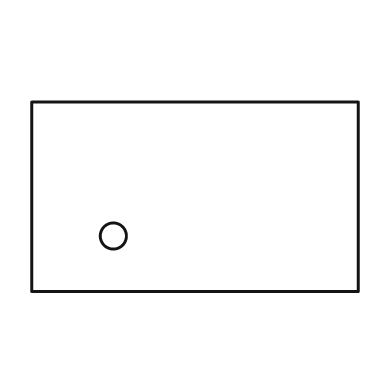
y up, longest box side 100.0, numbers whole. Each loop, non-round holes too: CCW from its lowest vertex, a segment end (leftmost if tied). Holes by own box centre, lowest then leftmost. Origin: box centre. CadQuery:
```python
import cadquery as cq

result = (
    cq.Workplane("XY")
    .moveTo(-50.0, -29.0)
    .lineTo(50.0, -29.0)
    .lineTo(50.0, 29.0)
    .lineTo(-50.0, 29.0)
    .close()
    .moveTo(-25.0, -12.0)
    .circle(4.0)
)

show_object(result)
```